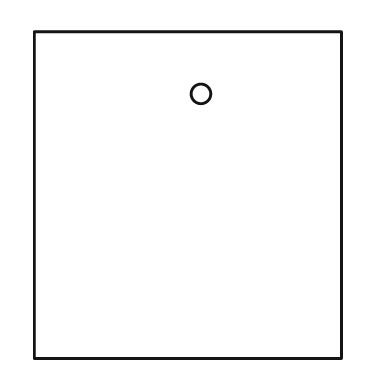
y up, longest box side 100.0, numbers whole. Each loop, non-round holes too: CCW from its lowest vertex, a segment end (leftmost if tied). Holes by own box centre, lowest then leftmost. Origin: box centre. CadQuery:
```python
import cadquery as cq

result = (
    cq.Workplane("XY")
    .moveTo(-47.0, -50.0)
    .lineTo(47.0, -50.0)
    .lineTo(47.0, 50.0)
    .lineTo(-47.0, 50.0)
    .close()
    .moveTo(4.0, 31.0)
    .circle(3.0)
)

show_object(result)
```